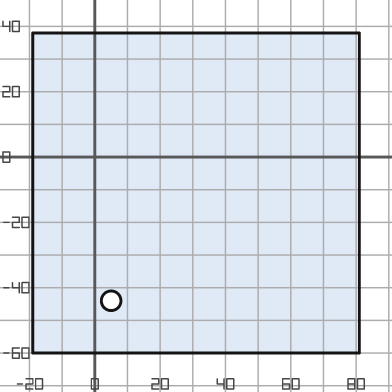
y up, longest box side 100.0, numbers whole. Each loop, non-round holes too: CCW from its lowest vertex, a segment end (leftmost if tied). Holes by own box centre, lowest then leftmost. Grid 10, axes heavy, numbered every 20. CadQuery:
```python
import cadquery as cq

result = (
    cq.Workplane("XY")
    .moveTo(-19.0, -60.0)
    .lineTo(81.0, -60.0)
    .lineTo(81.0, 38.0)
    .lineTo(-19.0, 38.0)
    .close()
    .moveTo(5.0, -44.0)
    .circle(3.0)
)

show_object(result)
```